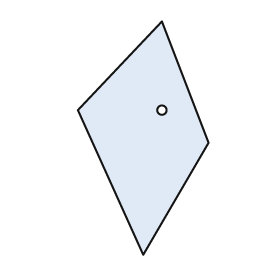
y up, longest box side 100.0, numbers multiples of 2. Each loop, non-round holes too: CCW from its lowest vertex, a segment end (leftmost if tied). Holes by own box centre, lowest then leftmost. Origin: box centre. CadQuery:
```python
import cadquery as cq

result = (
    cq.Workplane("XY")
    .moveTo(0.0, -50.0)
    .lineTo(28.0, -2.0)
    .lineTo(8.0, 50.0)
    .lineTo(-28.0, 12.0)
    .close()
    .moveTo(8.0, 12.0)
    .circle(2.0)
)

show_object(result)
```